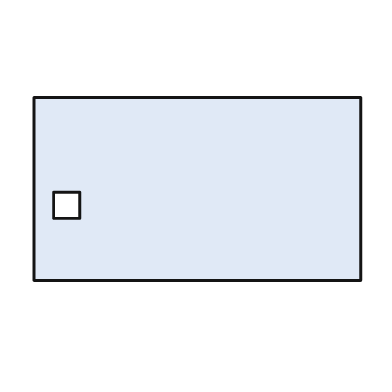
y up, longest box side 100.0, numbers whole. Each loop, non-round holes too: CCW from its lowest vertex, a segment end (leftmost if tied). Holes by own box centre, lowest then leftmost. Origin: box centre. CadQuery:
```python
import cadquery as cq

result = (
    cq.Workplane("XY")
    .moveTo(-50.0, -28.0)
    .lineTo(50.0, -28.0)
    .lineTo(50.0, 28.0)
    .lineTo(-50.0, 28.0)
    .close()
    .moveTo(-44.0, -9.0)
    .lineTo(-36.0, -9.0)
    .lineTo(-36.0, -1.0)
    .lineTo(-44.0, -1.0)
    .close()
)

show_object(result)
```